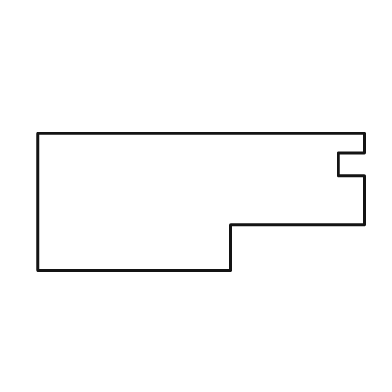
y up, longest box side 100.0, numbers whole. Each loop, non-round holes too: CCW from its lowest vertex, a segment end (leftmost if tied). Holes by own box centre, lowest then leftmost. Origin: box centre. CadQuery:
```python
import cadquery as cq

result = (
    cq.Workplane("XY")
    .moveTo(-50.0, -21.0)
    .lineTo(9.0, -21.0)
    .lineTo(9.0, -7.0)
    .lineTo(50.0, -7.0)
    .lineTo(50.0, 8.0)
    .lineTo(42.0, 8.0)
    .lineTo(42.0, 15.0)
    .lineTo(50.0, 15.0)
    .lineTo(50.0, 21.0)
    .lineTo(-50.0, 21.0)
    .close()
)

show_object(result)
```